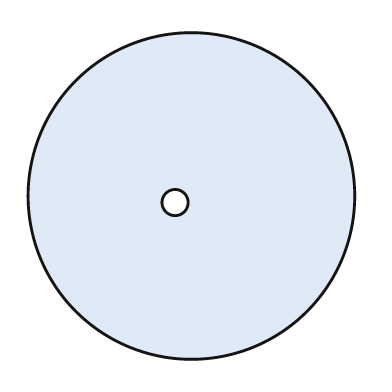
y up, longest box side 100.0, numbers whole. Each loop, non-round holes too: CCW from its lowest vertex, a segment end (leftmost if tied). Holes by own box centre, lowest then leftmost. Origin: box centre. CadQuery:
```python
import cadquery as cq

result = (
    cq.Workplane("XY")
    .moveTo(0.0, 0.0)
    .circle(50.0)
    .moveTo(-5.0, -2.0)
    .circle(4.0)
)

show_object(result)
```